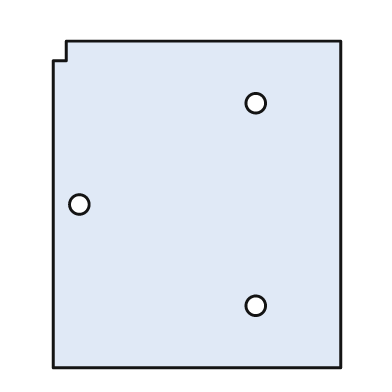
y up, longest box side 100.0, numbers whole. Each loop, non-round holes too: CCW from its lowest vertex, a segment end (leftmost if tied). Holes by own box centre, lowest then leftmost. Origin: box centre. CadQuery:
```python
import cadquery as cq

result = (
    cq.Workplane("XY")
    .moveTo(-44.0, -50.0)
    .lineTo(44.0, -50.0)
    .lineTo(44.0, 50.0)
    .lineTo(-40.0, 50.0)
    .lineTo(-40.0, 44.0)
    .lineTo(-44.0, 44.0)
    .close()
    .moveTo(18.0, -31.0)
    .circle(3.0)
    .moveTo(-36.0, 0.0)
    .circle(3.0)
    .moveTo(18.0, 31.0)
    .circle(3.0)
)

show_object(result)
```